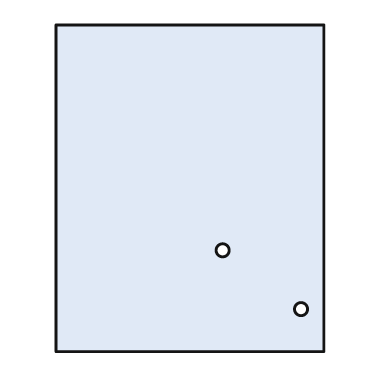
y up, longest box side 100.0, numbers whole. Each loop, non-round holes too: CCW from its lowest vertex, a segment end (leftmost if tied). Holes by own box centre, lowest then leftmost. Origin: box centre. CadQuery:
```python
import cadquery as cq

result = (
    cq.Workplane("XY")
    .moveTo(-41.0, -50.0)
    .lineTo(41.0, -50.0)
    .lineTo(41.0, 50.0)
    .lineTo(-41.0, 50.0)
    .close()
    .moveTo(34.0, -37.0)
    .circle(2.0)
    .moveTo(10.0, -19.0)
    .circle(2.0)
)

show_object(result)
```